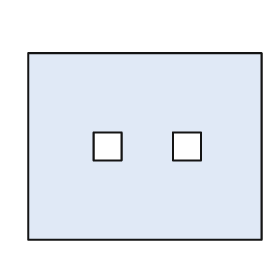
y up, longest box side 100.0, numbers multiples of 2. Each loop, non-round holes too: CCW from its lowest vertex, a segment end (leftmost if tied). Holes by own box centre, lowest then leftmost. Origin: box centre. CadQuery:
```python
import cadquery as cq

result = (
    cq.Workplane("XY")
    .moveTo(-50.0, -40.0)
    .lineTo(50.0, -40.0)
    .lineTo(50.0, 40.0)
    .lineTo(-50.0, 40.0)
    .close()
    .moveTo(-22.0, -6.0)
    .lineTo(-10.0, -6.0)
    .lineTo(-10.0, 6.0)
    .lineTo(-22.0, 6.0)
    .close()
    .moveTo(12.0, -6.0)
    .lineTo(24.0, -6.0)
    .lineTo(24.0, 6.0)
    .lineTo(12.0, 6.0)
    .close()
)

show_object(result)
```